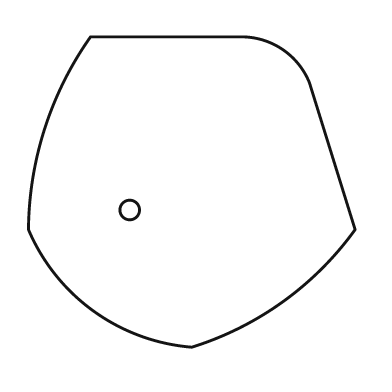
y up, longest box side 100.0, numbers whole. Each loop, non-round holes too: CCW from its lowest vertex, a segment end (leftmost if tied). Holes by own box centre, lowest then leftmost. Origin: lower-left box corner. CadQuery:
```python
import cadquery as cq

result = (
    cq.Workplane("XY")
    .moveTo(50.0, 0.0)
    .threePointArc((78.0, 14.0), (100.0, 36.0))
    .lineTo(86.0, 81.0)
    .threePointArc((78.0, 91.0), (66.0, 95.0))
    .lineTo(19.0, 95.0)
    .threePointArc((5.0, 67.0), (0.0, 36.0))
    .threePointArc((20.0, 11.0), (50.0, 0.0))
    .close()
    .moveTo(31.0, 42.0)
    .circle(3.0)
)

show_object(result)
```